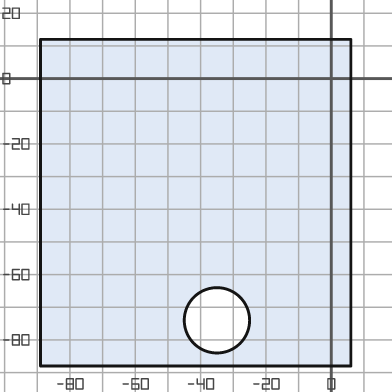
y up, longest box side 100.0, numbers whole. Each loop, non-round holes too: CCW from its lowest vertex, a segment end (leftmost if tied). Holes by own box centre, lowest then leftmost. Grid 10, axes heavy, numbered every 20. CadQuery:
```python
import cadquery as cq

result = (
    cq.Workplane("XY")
    .moveTo(-89.0, -88.0)
    .lineTo(6.0, -88.0)
    .lineTo(6.0, 12.0)
    .lineTo(-89.0, 12.0)
    .close()
    .moveTo(-35.0, -74.0)
    .circle(10.0)
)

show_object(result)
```